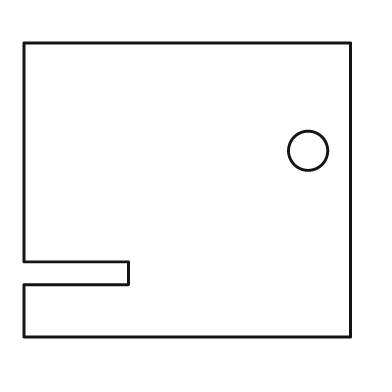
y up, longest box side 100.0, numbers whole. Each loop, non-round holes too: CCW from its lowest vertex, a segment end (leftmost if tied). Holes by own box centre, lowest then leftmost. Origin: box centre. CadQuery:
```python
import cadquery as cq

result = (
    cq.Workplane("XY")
    .moveTo(-50.0, -45.0)
    .lineTo(50.0, -45.0)
    .lineTo(50.0, 45.0)
    .lineTo(-50.0, 45.0)
    .lineTo(-50.0, -22.0)
    .lineTo(-18.0, -22.0)
    .lineTo(-18.0, -29.0)
    .lineTo(-50.0, -29.0)
    .close()
    .moveTo(37.0, 12.0)
    .circle(6.0)
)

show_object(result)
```